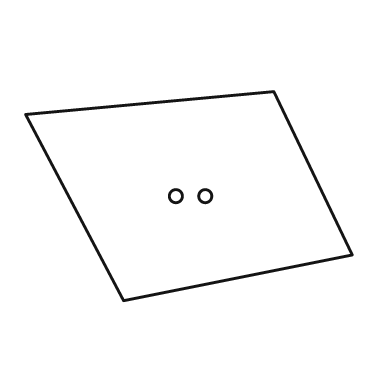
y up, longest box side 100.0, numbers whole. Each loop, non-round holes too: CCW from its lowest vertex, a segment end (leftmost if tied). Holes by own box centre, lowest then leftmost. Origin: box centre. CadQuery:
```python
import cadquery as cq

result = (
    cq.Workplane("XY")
    .moveTo(-20.0, -32.0)
    .lineTo(50.0, -18.0)
    .lineTo(26.0, 32.0)
    .lineTo(-50.0, 25.0)
    .close()
    .moveTo(-4.0, 0.0)
    .circle(2.0)
    .moveTo(5.0, 0.0)
    .circle(2.0)
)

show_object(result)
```